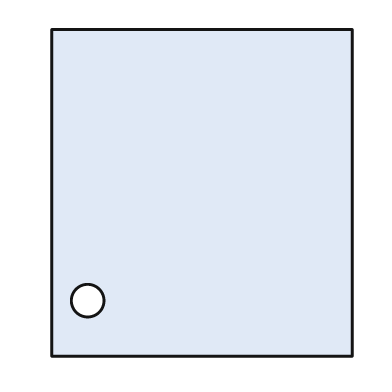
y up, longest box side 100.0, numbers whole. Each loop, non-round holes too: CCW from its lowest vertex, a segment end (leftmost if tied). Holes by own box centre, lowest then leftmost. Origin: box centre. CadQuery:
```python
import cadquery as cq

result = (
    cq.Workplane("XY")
    .moveTo(-46.0, -50.0)
    .lineTo(46.0, -50.0)
    .lineTo(46.0, 50.0)
    .lineTo(-46.0, 50.0)
    .close()
    .moveTo(-35.0, -33.0)
    .circle(5.0)
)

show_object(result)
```